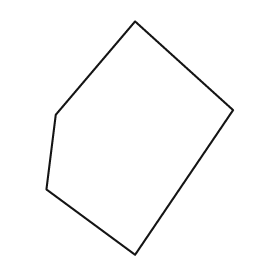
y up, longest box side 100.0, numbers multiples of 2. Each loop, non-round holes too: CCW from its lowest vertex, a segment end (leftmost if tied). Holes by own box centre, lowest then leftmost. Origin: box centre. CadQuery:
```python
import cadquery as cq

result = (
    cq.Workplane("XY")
    .moveTo(-2.0, -50.0)
    .lineTo(40.0, 12.0)
    .lineTo(-2.0, 50.0)
    .lineTo(-36.0, 10.0)
    .lineTo(-40.0, -22.0)
    .close()
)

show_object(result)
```